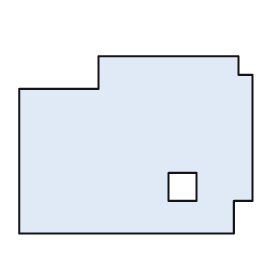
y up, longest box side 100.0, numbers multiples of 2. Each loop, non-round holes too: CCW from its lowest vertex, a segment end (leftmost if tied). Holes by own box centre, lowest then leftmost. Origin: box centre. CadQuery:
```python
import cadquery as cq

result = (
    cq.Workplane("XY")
    .moveTo(-50.0, -38.0)
    .lineTo(42.0, -38.0)
    .lineTo(42.0, -24.0)
    .lineTo(50.0, -24.0)
    .lineTo(50.0, 30.0)
    .lineTo(44.0, 30.0)
    .lineTo(44.0, 38.0)
    .lineTo(-16.0, 38.0)
    .lineTo(-16.0, 24.0)
    .lineTo(-50.0, 24.0)
    .close()
    .moveTo(14.0, -24.0)
    .lineTo(26.0, -24.0)
    .lineTo(26.0, -12.0)
    .lineTo(14.0, -12.0)
    .close()
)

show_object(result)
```